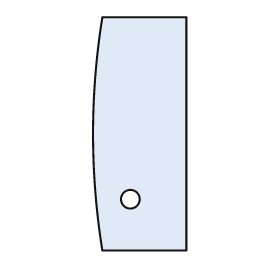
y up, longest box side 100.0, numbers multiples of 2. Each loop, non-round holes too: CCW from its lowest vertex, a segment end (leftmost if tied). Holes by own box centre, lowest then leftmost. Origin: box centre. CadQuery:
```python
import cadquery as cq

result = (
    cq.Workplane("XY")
    .moveTo(-16.0, -50.0)
    .lineTo(20.0, -50.0)
    .lineTo(20.0, 50.0)
    .lineTo(-16.0, 50.0)
    .threePointArc((-20.0, 0.0), (-16.0, -50.0))
    .close()
    .moveTo(-4.0, -28.0)
    .circle(4.0)
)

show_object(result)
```